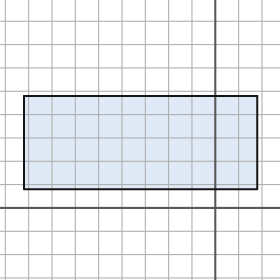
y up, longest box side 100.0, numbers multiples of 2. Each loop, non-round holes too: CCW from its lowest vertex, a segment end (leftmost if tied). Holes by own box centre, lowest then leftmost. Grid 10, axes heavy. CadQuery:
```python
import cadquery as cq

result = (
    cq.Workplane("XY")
    .moveTo(-82.0, 8.0)
    .lineTo(18.0, 8.0)
    .lineTo(18.0, 48.0)
    .lineTo(-82.0, 48.0)
    .close()
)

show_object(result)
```